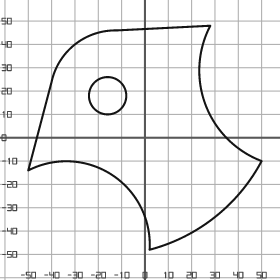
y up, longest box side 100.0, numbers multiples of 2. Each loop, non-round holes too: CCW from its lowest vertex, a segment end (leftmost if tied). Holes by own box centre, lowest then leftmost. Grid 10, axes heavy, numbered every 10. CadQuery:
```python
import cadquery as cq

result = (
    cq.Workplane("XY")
    .moveTo(2.0, -48.0)
    .threePointArc((30.0, -34.0), (50.0, -10.0))
    .threePointArc((26.0, 14.0), (28.0, 48.0))
    .lineTo(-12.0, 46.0)
    .threePointArc((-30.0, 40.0), (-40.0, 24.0))
    .lineTo(-50.0, -14.0)
    .threePointArc((-14.0, -16.0), (2.0, -48.0))
    .close()
    .moveTo(-16.0, 18.0)
    .circle(8.0)
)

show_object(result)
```